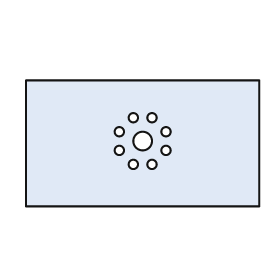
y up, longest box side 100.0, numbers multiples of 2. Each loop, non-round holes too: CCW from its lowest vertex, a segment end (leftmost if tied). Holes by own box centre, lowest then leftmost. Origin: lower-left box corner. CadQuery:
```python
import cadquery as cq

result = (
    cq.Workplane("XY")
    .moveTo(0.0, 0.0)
    .lineTo(100.0, 0.0)
    .lineTo(100.0, 54.0)
    .lineTo(0.0, 54.0)
    .close()
    .moveTo(46.0, 18.0)
    .circle(2.0)
    .moveTo(54.0, 18.0)
    .circle(2.0)
    .moveTo(40.0, 24.0)
    .circle(2.0)
    .moveTo(60.0, 24.0)
    .circle(2.0)
    .moveTo(50.0, 28.0)
    .circle(4.0)
    .moveTo(40.0, 32.0)
    .circle(2.0)
    .moveTo(60.0, 32.0)
    .circle(2.0)
    .moveTo(46.0, 38.0)
    .circle(2.0)
    .moveTo(54.0, 38.0)
    .circle(2.0)
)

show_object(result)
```